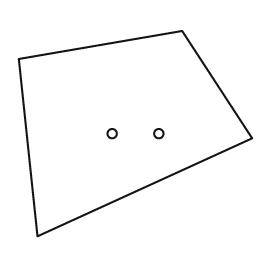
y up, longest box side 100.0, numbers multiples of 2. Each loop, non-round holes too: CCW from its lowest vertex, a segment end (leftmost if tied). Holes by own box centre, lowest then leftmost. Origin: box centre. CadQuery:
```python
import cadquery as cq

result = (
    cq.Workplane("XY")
    .moveTo(-42.0, -44.0)
    .lineTo(50.0, -2.0)
    .lineTo(20.0, 44.0)
    .lineTo(-50.0, 32.0)
    .close()
    .moveTo(-10.0, 0.0)
    .circle(2.0)
    .moveTo(10.0, 0.0)
    .circle(2.0)
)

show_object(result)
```